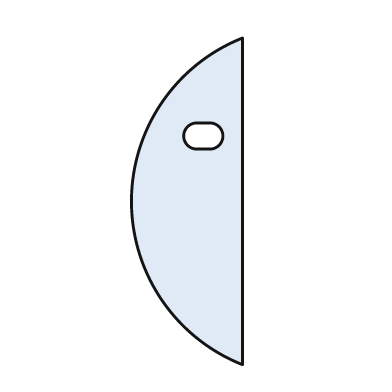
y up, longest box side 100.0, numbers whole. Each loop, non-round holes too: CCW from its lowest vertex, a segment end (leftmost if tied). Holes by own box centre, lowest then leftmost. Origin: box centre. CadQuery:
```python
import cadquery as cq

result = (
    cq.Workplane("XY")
    .moveTo(17.0, -50.0)
    .lineTo(17.0, 50.0)
    .threePointArc((-17.0, 0.0), (17.0, -50.0))
    .close()
    .moveTo(3.0, 16.0)
    .lineTo(7.0, 16.0)
    .threePointArc((11.0, 20.0), (7.0, 24.0))
    .lineTo(3.0, 24.0)
    .threePointArc((-1.0, 20.0), (3.0, 16.0))
    .close()
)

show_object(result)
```